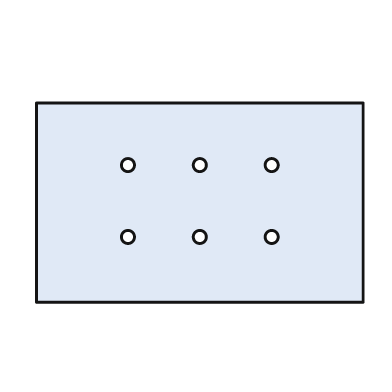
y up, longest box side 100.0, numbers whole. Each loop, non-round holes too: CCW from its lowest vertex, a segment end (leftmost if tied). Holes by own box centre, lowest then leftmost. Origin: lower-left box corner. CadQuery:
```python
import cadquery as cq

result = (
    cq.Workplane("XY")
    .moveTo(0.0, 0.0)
    .lineTo(100.0, 0.0)
    .lineTo(100.0, 61.0)
    .lineTo(0.0, 61.0)
    .close()
    .moveTo(28.0, 20.0)
    .circle(2.0)
    .moveTo(50.0, 20.0)
    .circle(2.0)
    .moveTo(72.0, 20.0)
    .circle(2.0)
    .moveTo(28.0, 42.0)
    .circle(2.0)
    .moveTo(50.0, 42.0)
    .circle(2.0)
    .moveTo(72.0, 42.0)
    .circle(2.0)
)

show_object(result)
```